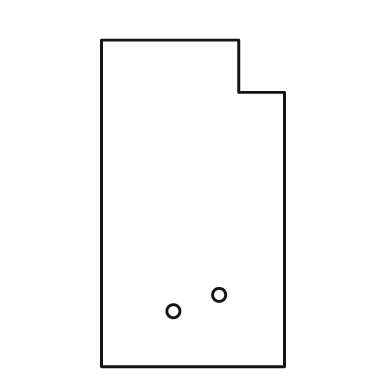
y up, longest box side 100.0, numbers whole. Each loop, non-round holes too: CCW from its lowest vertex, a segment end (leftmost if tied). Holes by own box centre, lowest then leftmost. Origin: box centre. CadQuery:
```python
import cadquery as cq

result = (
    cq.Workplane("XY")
    .moveTo(-28.0, -50.0)
    .lineTo(28.0, -50.0)
    .lineTo(28.0, 34.0)
    .lineTo(14.0, 34.0)
    .lineTo(14.0, 50.0)
    .lineTo(-28.0, 50.0)
    .close()
    .moveTo(-6.0, -33.0)
    .circle(2.0)
    .moveTo(8.0, -28.0)
    .circle(2.0)
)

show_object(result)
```